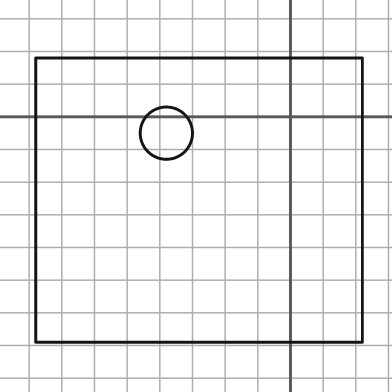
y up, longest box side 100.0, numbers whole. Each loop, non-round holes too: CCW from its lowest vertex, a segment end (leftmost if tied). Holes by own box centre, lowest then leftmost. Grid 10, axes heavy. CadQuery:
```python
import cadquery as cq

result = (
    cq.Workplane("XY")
    .moveTo(-78.0, -69.0)
    .lineTo(22.0, -69.0)
    .lineTo(22.0, 18.0)
    .lineTo(-78.0, 18.0)
    .close()
    .moveTo(-38.0, -5.0)
    .circle(8.0)
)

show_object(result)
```